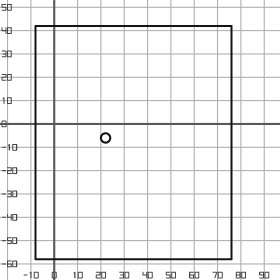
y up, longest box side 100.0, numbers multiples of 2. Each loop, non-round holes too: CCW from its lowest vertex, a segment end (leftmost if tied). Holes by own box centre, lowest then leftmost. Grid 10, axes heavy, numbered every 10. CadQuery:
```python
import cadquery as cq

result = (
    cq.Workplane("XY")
    .moveTo(-8.0, -58.0)
    .lineTo(76.0, -58.0)
    .lineTo(76.0, 42.0)
    .lineTo(-8.0, 42.0)
    .close()
    .moveTo(22.0, -6.0)
    .circle(2.0)
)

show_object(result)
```